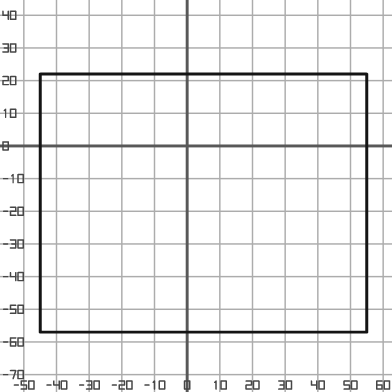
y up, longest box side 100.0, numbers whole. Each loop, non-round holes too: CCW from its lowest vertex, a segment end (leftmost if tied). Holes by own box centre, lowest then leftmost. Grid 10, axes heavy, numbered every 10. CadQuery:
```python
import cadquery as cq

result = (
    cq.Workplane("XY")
    .moveTo(-45.0, -57.0)
    .lineTo(55.0, -57.0)
    .lineTo(55.0, 22.0)
    .lineTo(-45.0, 22.0)
    .close()
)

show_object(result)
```